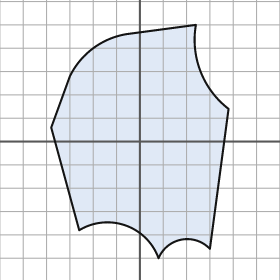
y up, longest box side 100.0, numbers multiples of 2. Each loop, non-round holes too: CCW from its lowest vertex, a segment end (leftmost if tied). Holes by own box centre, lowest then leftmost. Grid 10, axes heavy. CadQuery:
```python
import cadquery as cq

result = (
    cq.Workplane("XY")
    .moveTo(8.0, -50.0)
    .threePointArc((18.0, -42.0), (30.0, -46.0))
    .lineTo(38.0, 14.0)
    .threePointArc((26.0, 30.0), (24.0, 50.0))
    .lineTo(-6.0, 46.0)
    .threePointArc((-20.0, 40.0), (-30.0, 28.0))
    .lineTo(-38.0, 6.0)
    .lineTo(-26.0, -38.0)
    .threePointArc((-6.0, -36.0), (8.0, -50.0))
    .close()
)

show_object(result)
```